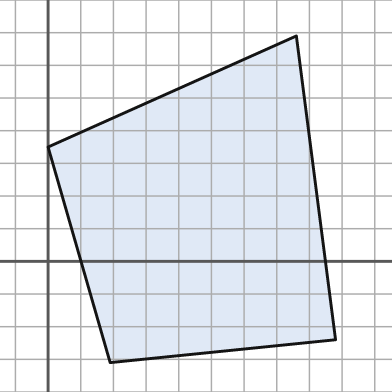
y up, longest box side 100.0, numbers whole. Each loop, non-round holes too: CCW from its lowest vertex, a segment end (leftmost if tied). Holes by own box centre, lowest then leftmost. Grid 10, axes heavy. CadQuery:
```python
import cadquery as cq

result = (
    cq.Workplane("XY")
    .moveTo(19.0, -31.0)
    .lineTo(88.0, -24.0)
    .lineTo(76.0, 69.0)
    .lineTo(0.0, 35.0)
    .close()
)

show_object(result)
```